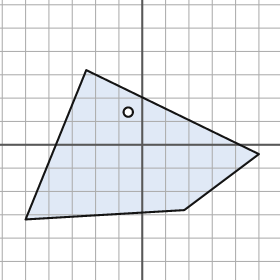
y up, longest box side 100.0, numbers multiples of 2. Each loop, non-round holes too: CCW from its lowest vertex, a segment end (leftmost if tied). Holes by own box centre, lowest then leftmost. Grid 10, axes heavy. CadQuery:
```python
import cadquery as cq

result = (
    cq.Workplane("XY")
    .moveTo(-50.0, -32.0)
    .lineTo(18.0, -28.0)
    .lineTo(50.0, -4.0)
    .lineTo(-24.0, 32.0)
    .close()
    .moveTo(-6.0, 14.0)
    .circle(2.0)
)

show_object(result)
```